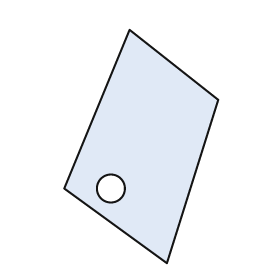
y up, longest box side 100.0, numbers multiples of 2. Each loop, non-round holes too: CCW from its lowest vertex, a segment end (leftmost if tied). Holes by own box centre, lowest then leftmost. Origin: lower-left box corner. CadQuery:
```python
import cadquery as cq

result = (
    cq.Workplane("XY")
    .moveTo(44.0, 0.0)
    .lineTo(66.0, 70.0)
    .lineTo(28.0, 100.0)
    .lineTo(0.0, 32.0)
    .close()
    .moveTo(20.0, 32.0)
    .circle(6.0)
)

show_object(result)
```